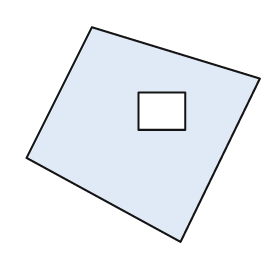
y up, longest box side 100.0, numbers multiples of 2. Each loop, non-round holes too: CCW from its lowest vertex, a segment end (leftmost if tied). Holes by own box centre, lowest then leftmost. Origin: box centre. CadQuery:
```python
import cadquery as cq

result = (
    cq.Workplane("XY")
    .moveTo(16.0, -46.0)
    .lineTo(50.0, 24.0)
    .lineTo(-22.0, 46.0)
    .lineTo(-50.0, -10.0)
    .close()
    .moveTo(-2.0, 2.0)
    .lineTo(18.0, 2.0)
    .lineTo(18.0, 18.0)
    .lineTo(-2.0, 18.0)
    .close()
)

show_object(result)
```